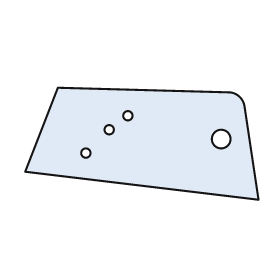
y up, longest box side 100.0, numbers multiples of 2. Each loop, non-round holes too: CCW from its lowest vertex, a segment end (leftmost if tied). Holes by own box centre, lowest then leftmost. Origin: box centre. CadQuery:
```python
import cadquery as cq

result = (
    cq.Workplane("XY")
    .moveTo(50.0, -24.0)
    .lineTo(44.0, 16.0)
    .threePointArc((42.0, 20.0), (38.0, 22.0))
    .lineTo(-36.0, 24.0)
    .lineTo(-50.0, -12.0)
    .close()
    .moveTo(-24.0, -4.0)
    .circle(2.0)
    .moveTo(34.0, 2.0)
    .circle(4.0)
    .moveTo(-14.0, 6.0)
    .circle(2.0)
    .moveTo(-6.0, 12.0)
    .circle(2.0)
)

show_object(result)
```